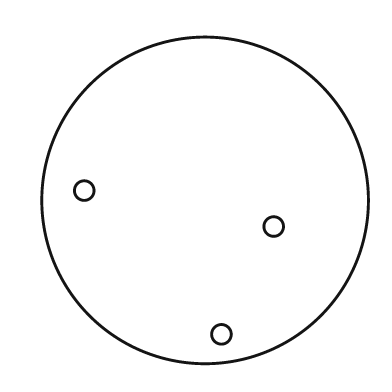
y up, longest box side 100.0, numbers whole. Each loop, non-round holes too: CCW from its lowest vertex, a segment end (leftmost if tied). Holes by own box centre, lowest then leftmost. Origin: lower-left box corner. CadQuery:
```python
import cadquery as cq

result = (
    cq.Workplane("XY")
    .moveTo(50.0, 50.0)
    .circle(50.0)
    .moveTo(55.0, 9.0)
    .circle(3.0)
    .moveTo(71.0, 42.0)
    .circle(3.0)
    .moveTo(13.0, 53.0)
    .circle(3.0)
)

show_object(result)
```